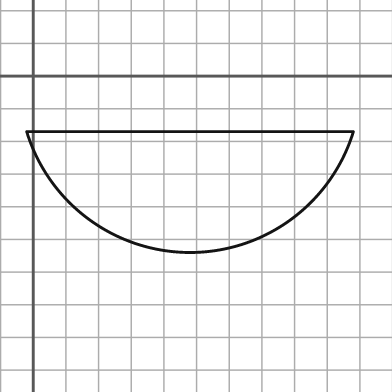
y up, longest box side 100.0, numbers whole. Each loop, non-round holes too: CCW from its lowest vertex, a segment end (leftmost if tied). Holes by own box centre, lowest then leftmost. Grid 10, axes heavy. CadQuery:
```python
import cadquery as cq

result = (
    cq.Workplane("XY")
    .moveTo(-2.0, -17.0)
    .threePointArc((48.0, -54.0), (98.0, -17.0))
    .close()
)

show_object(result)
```